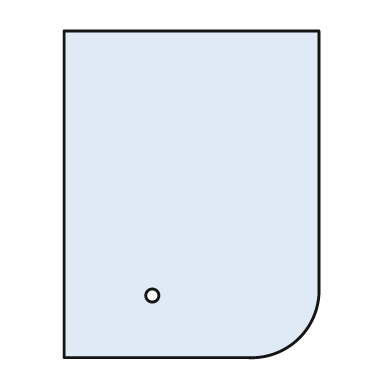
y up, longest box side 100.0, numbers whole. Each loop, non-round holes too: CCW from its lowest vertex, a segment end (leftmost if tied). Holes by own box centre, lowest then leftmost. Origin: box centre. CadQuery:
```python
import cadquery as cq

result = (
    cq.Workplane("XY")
    .moveTo(-39.0, -50.0)
    .lineTo(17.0, -50.0)
    .threePointArc((33.0, -44.0), (39.0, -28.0))
    .lineTo(39.0, 50.0)
    .lineTo(-39.0, 50.0)
    .close()
    .moveTo(-12.0, -31.0)
    .circle(2.0)
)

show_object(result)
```